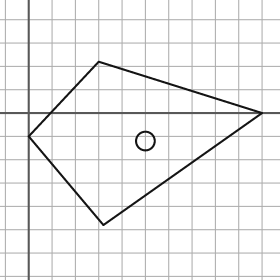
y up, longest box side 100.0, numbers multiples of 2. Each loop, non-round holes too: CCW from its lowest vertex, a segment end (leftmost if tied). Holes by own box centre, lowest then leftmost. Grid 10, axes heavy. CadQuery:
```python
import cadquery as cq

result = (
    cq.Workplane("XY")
    .moveTo(32.0, -48.0)
    .lineTo(100.0, 0.0)
    .lineTo(30.0, 22.0)
    .lineTo(0.0, -10.0)
    .close()
    .moveTo(50.0, -12.0)
    .circle(4.0)
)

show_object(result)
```